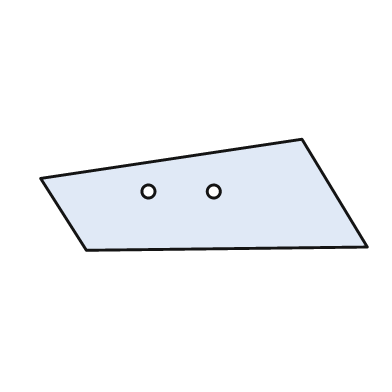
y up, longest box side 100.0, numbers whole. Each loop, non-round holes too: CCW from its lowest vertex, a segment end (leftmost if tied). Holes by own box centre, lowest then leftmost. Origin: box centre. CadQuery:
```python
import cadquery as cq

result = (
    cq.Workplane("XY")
    .moveTo(-36.0, -17.0)
    .lineTo(50.0, -16.0)
    .lineTo(30.0, 17.0)
    .lineTo(-50.0, 5.0)
    .close()
    .moveTo(-17.0, 1.0)
    .circle(2.0)
    .moveTo(3.0, 1.0)
    .circle(2.0)
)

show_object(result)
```